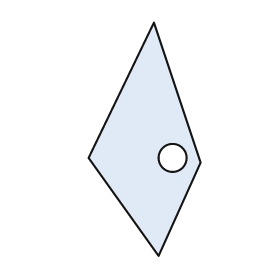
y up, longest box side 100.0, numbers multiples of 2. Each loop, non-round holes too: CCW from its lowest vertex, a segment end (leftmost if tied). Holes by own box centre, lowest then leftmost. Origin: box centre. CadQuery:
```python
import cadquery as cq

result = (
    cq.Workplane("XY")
    .moveTo(6.0, -50.0)
    .lineTo(24.0, -10.0)
    .lineTo(4.0, 50.0)
    .lineTo(-24.0, -8.0)
    .close()
    .moveTo(12.0, -8.0)
    .circle(6.0)
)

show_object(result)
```